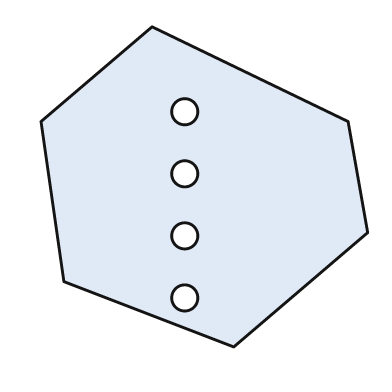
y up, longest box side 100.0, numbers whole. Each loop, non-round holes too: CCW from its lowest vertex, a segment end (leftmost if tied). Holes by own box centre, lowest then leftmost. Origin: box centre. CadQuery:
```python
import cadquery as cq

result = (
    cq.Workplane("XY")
    .moveTo(9.0, -49.0)
    .lineTo(50.0, -14.0)
    .lineTo(44.0, 20.0)
    .lineTo(-16.0, 49.0)
    .lineTo(-50.0, 20.0)
    .lineTo(-43.0, -29.0)
    .close()
    .moveTo(-6.0, -34.0)
    .circle(4.0)
    .moveTo(-6.0, -15.0)
    .circle(4.0)
    .moveTo(-6.0, 4.0)
    .circle(4.0)
    .moveTo(-6.0, 23.0)
    .circle(4.0)
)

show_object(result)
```